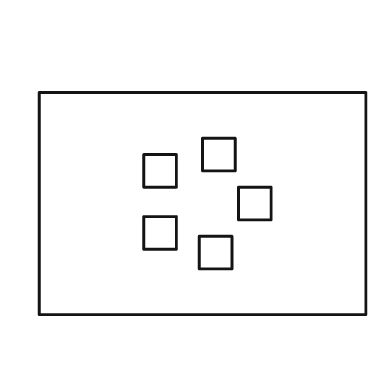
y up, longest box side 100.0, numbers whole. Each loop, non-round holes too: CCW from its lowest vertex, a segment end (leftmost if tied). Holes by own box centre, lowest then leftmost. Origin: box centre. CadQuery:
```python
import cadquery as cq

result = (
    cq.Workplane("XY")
    .moveTo(-50.0, -34.0)
    .lineTo(50.0, -34.0)
    .lineTo(50.0, 34.0)
    .lineTo(-50.0, 34.0)
    .close()
    .moveTo(-1.0, -20.0)
    .lineTo(9.0, -20.0)
    .lineTo(9.0, -10.0)
    .lineTo(-1.0, -10.0)
    .close()
    .moveTo(-18.0, -14.0)
    .lineTo(-8.0, -14.0)
    .lineTo(-8.0, -4.0)
    .lineTo(-18.0, -4.0)
    .close()
    .moveTo(11.0, -5.0)
    .lineTo(21.0, -5.0)
    .lineTo(21.0, 5.0)
    .lineTo(11.0, 5.0)
    .close()
    .moveTo(-18.0, 5.0)
    .lineTo(-8.0, 5.0)
    .lineTo(-8.0, 15.0)
    .lineTo(-18.0, 15.0)
    .close()
    .moveTo(0.0, 10.0)
    .lineTo(10.0, 10.0)
    .lineTo(10.0, 20.0)
    .lineTo(0.0, 20.0)
    .close()
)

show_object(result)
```